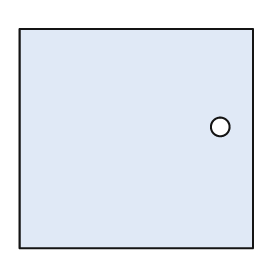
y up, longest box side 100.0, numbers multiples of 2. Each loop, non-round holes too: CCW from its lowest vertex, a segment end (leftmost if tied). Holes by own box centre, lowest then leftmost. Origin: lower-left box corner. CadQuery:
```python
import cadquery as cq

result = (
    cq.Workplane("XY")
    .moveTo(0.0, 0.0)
    .lineTo(100.0, 0.0)
    .lineTo(100.0, 94.0)
    .lineTo(0.0, 94.0)
    .close()
    .moveTo(86.0, 52.0)
    .circle(4.0)
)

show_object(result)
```